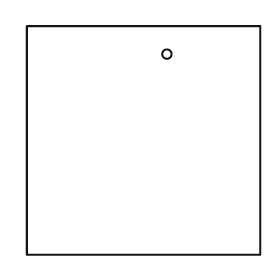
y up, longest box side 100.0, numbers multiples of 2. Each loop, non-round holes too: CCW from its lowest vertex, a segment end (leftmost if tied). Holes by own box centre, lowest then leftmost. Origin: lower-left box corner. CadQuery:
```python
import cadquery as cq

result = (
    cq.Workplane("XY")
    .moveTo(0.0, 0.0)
    .lineTo(100.0, 0.0)
    .lineTo(100.0, 98.0)
    .lineTo(0.0, 98.0)
    .close()
    .moveTo(60.0, 86.0)
    .circle(2.0)
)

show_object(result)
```